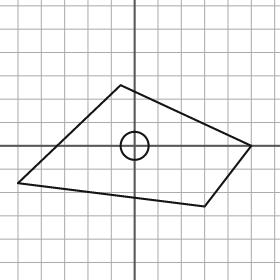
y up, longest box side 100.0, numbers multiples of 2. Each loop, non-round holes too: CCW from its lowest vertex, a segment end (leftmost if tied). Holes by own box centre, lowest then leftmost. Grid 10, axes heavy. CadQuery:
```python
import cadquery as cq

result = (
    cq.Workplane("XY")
    .moveTo(30.0, -26.0)
    .lineTo(50.0, 0.0)
    .lineTo(-6.0, 26.0)
    .lineTo(-50.0, -16.0)
    .close()
    .moveTo(0.0, 0.0)
    .circle(6.0)
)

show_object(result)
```